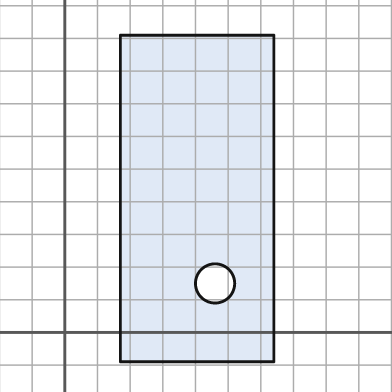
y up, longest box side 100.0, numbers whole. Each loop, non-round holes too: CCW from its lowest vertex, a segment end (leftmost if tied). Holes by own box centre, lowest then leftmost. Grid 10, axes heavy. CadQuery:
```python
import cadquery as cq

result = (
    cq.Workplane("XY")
    .moveTo(17.0, -9.0)
    .lineTo(64.0, -9.0)
    .lineTo(64.0, 91.0)
    .lineTo(17.0, 91.0)
    .close()
    .moveTo(46.0, 15.0)
    .circle(6.0)
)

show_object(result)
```